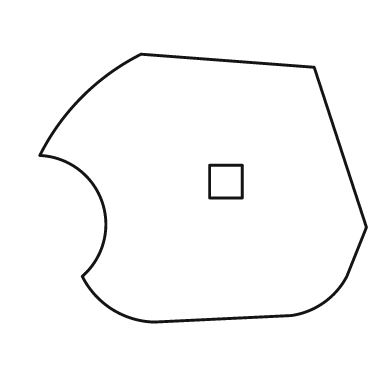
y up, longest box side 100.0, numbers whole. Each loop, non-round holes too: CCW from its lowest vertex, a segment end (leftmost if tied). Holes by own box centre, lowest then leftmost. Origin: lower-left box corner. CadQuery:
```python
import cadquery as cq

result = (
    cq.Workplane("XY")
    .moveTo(35.0, 0.0)
    .lineTo(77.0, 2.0)
    .threePointArc((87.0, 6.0), (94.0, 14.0))
    .lineTo(100.0, 29.0)
    .lineTo(84.0, 78.0)
    .lineTo(31.0, 82.0)
    .threePointArc((13.0, 69.0), (0.0, 51.0))
    .threePointArc((19.0, 37.0), (13.0, 14.0))
    .threePointArc((22.0, 4.0), (35.0, 0.0))
    .close()
    .moveTo(52.0, 38.0)
    .lineTo(62.0, 38.0)
    .lineTo(62.0, 48.0)
    .lineTo(52.0, 48.0)
    .close()
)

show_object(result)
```